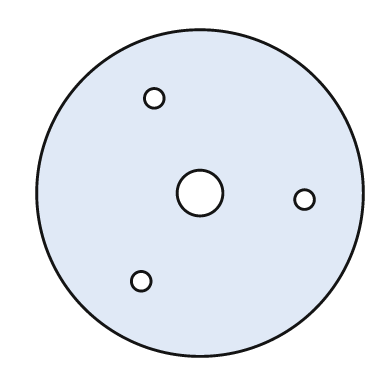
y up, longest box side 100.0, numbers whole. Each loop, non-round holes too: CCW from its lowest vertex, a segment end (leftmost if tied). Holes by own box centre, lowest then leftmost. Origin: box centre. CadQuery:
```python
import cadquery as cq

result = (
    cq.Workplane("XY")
    .moveTo(0.0, 0.0)
    .circle(50.0)
    .moveTo(-18.0, -27.0)
    .circle(3.0)
    .moveTo(32.0, -2.0)
    .circle(3.0)
    .moveTo(0.0, 0.0)
    .circle(7.0)
    .moveTo(-14.0, 29.0)
    .circle(3.0)
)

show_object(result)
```